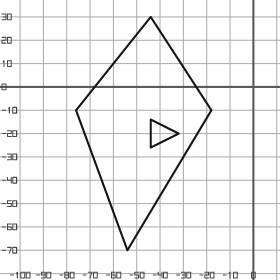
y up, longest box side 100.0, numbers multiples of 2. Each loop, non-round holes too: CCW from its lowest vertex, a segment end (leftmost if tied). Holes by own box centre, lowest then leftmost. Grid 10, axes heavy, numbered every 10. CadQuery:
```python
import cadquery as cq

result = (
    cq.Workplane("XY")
    .moveTo(-54.0, -70.0)
    .lineTo(-18.0, -10.0)
    .lineTo(-44.0, 30.0)
    .lineTo(-76.0, -10.0)
    .close()
    .moveTo(-44.0, -26.0)
    .lineTo(-32.0, -20.0)
    .lineTo(-44.0, -14.0)
    .close()
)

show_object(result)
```